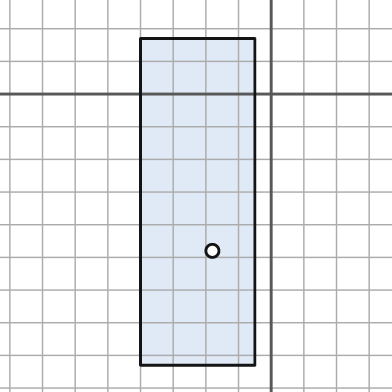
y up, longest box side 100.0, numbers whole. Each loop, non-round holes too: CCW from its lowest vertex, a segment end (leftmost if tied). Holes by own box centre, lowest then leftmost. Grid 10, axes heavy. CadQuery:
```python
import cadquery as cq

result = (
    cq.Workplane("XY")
    .moveTo(-40.0, -83.0)
    .lineTo(-5.0, -83.0)
    .lineTo(-5.0, 17.0)
    .lineTo(-40.0, 17.0)
    .close()
    .moveTo(-18.0, -48.0)
    .circle(2.0)
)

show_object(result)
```